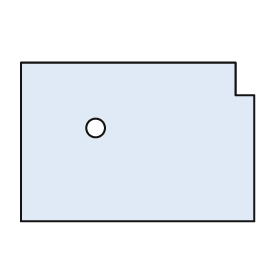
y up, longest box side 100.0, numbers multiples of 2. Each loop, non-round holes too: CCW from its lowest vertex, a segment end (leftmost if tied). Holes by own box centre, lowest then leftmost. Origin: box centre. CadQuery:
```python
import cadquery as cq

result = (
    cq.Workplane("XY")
    .moveTo(-50.0, -34.0)
    .lineTo(50.0, -34.0)
    .lineTo(50.0, 20.0)
    .lineTo(42.0, 20.0)
    .lineTo(42.0, 34.0)
    .lineTo(-50.0, 34.0)
    .close()
    .moveTo(-18.0, 6.0)
    .circle(4.0)
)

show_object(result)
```